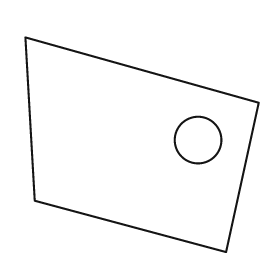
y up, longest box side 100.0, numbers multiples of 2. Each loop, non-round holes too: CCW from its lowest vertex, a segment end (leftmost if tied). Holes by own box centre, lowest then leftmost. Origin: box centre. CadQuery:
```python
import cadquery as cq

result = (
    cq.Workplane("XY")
    .moveTo(36.0, -46.0)
    .lineTo(50.0, 18.0)
    .lineTo(-50.0, 46.0)
    .lineTo(-46.0, -24.0)
    .close()
    .moveTo(24.0, 2.0)
    .circle(10.0)
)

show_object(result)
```